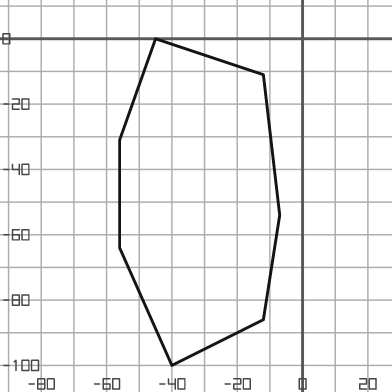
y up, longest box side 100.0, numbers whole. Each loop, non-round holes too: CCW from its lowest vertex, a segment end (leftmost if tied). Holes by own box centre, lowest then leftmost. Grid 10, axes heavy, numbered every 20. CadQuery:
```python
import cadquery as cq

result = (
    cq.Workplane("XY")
    .moveTo(-40.0, -100.0)
    .lineTo(-12.0, -86.0)
    .lineTo(-7.0, -54.0)
    .lineTo(-12.0, -11.0)
    .lineTo(-45.0, 0.0)
    .lineTo(-56.0, -31.0)
    .lineTo(-56.0, -64.0)
    .close()
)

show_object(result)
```